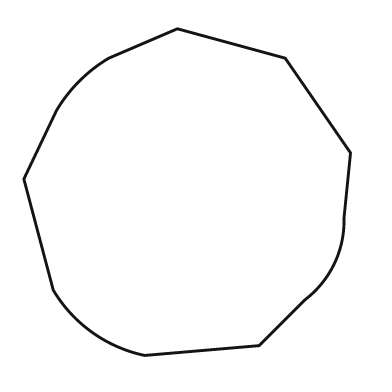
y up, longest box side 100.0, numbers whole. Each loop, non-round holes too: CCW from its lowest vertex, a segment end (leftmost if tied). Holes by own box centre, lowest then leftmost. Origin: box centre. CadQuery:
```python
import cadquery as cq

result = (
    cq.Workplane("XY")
    .moveTo(-13.0, -50.0)
    .lineTo(22.0, -47.0)
    .lineTo(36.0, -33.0)
    .threePointArc((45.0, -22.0), (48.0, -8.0))
    .lineTo(50.0, 12.0)
    .lineTo(30.0, 41.0)
    .lineTo(-3.0, 50.0)
    .lineTo(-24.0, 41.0)
    .threePointArc((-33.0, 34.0), (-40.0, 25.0))
    .lineTo(-50.0, 4.0)
    .lineTo(-41.0, -30.0)
    .threePointArc((-29.0, -43.0), (-13.0, -50.0))
    .close()
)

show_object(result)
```